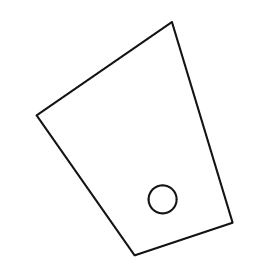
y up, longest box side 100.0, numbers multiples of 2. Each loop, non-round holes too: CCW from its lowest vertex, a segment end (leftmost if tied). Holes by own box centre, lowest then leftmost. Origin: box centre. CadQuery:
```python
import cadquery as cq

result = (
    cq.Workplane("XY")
    .moveTo(0.0, -50.0)
    .lineTo(42.0, -36.0)
    .lineTo(16.0, 50.0)
    .lineTo(-42.0, 10.0)
    .close()
    .moveTo(12.0, -26.0)
    .circle(6.0)
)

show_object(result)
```